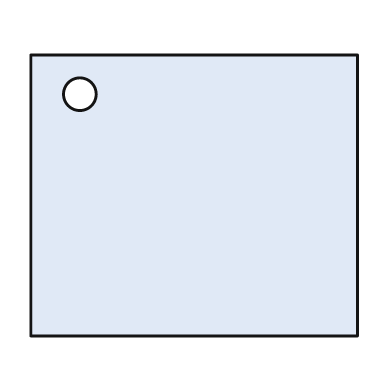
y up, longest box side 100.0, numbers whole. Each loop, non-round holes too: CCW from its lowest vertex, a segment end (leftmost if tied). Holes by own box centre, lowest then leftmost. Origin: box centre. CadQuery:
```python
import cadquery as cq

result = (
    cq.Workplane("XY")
    .moveTo(-50.0, -43.0)
    .lineTo(50.0, -43.0)
    .lineTo(50.0, 43.0)
    .lineTo(-50.0, 43.0)
    .close()
    .moveTo(-35.0, 31.0)
    .circle(5.0)
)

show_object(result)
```